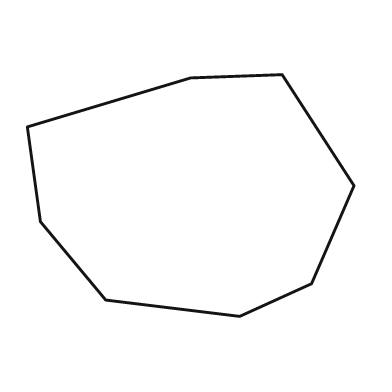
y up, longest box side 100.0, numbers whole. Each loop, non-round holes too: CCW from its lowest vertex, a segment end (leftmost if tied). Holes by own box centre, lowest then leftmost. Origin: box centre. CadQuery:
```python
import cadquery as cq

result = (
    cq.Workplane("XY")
    .moveTo(15.0, -37.0)
    .lineTo(37.0, -27.0)
    .lineTo(50.0, 3.0)
    .lineTo(28.0, 37.0)
    .lineTo(0.0, 36.0)
    .lineTo(-50.0, 21.0)
    .lineTo(-46.0, -8.0)
    .lineTo(-26.0, -32.0)
    .close()
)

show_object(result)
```